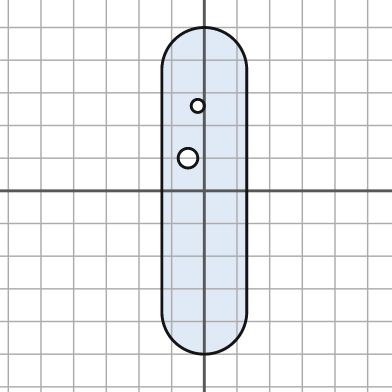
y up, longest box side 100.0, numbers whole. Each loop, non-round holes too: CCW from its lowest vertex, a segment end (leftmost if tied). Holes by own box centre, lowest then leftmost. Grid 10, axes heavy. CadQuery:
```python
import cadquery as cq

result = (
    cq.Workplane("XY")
    .moveTo(-13.0, -37.0)
    .threePointArc((0.0, -50.0), (13.0, -37.0))
    .lineTo(13.0, 37.0)
    .threePointArc((0.0, 50.0), (-13.0, 37.0))
    .close()
    .moveTo(-5.0, 10.0)
    .circle(3.0)
    .moveTo(-2.0, 26.0)
    .circle(2.0)
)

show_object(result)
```